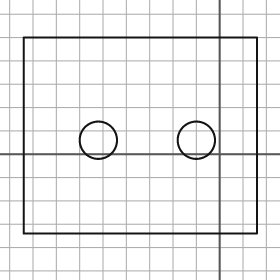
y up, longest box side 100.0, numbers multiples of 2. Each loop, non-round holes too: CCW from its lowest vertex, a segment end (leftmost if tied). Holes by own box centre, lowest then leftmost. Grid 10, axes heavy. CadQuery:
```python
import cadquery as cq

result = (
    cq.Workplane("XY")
    .moveTo(-84.0, -34.0)
    .lineTo(16.0, -34.0)
    .lineTo(16.0, 50.0)
    .lineTo(-84.0, 50.0)
    .close()
    .moveTo(-52.0, 6.0)
    .circle(8.0)
    .moveTo(-10.0, 6.0)
    .circle(8.0)
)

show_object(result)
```